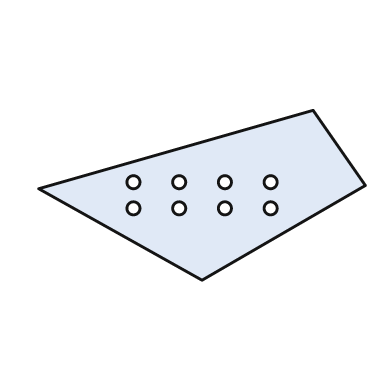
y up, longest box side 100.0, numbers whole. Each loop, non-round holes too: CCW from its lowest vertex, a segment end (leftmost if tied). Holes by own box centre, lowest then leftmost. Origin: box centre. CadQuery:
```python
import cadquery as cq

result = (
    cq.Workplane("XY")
    .moveTo(0.0, -26.0)
    .lineTo(50.0, 3.0)
    .lineTo(34.0, 26.0)
    .lineTo(-50.0, 2.0)
    .close()
    .moveTo(-21.0, -4.0)
    .circle(2.0)
    .moveTo(-7.0, -4.0)
    .circle(2.0)
    .moveTo(7.0, -4.0)
    .circle(2.0)
    .moveTo(21.0, -4.0)
    .circle(2.0)
    .moveTo(-21.0, 4.0)
    .circle(2.0)
    .moveTo(-7.0, 4.0)
    .circle(2.0)
    .moveTo(7.0, 4.0)
    .circle(2.0)
    .moveTo(21.0, 4.0)
    .circle(2.0)
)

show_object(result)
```